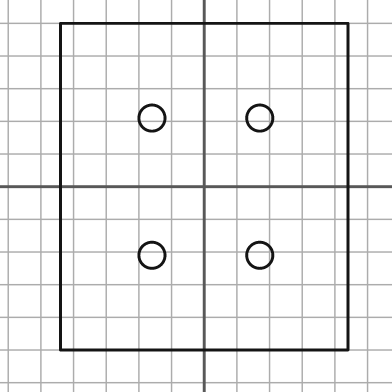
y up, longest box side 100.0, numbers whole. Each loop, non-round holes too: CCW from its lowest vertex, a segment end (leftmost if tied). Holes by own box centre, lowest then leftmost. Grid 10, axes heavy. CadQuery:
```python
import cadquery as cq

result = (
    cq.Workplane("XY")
    .moveTo(-44.0, -50.0)
    .lineTo(44.0, -50.0)
    .lineTo(44.0, 50.0)
    .lineTo(-44.0, 50.0)
    .close()
    .moveTo(-16.0, -21.0)
    .circle(4.0)
    .moveTo(17.0, -21.0)
    .circle(4.0)
    .moveTo(-16.0, 21.0)
    .circle(4.0)
    .moveTo(17.0, 21.0)
    .circle(4.0)
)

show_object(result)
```